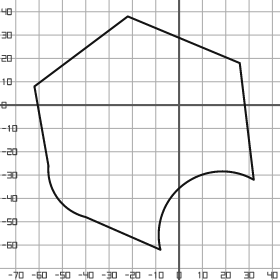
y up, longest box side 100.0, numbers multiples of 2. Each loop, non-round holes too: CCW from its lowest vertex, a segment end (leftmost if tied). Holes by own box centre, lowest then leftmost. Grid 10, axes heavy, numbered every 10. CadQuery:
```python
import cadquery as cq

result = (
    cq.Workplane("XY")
    .moveTo(-8.0, -62.0)
    .threePointArc((2.0, -34.0), (32.0, -32.0))
    .lineTo(26.0, 18.0)
    .lineTo(-22.0, 38.0)
    .lineTo(-62.0, 8.0)
    .lineTo(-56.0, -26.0)
    .threePointArc((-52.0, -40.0), (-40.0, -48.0))
    .close()
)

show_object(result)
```